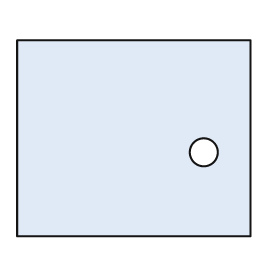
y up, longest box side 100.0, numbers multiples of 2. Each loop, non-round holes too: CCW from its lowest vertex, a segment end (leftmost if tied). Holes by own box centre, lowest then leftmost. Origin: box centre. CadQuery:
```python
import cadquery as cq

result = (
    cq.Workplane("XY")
    .moveTo(-50.0, -42.0)
    .lineTo(50.0, -42.0)
    .lineTo(50.0, 42.0)
    .lineTo(-50.0, 42.0)
    .close()
    .moveTo(30.0, -6.0)
    .circle(6.0)
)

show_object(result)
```